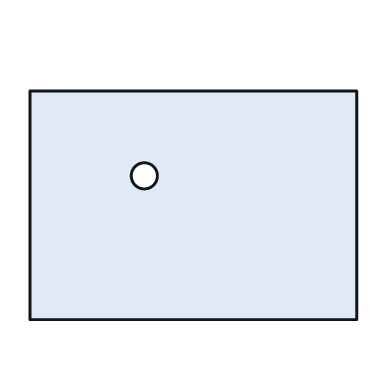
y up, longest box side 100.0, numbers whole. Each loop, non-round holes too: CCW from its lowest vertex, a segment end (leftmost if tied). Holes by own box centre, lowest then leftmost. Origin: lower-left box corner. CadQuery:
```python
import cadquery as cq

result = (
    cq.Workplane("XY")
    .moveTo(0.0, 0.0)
    .lineTo(100.0, 0.0)
    .lineTo(100.0, 70.0)
    .lineTo(0.0, 70.0)
    .close()
    .moveTo(35.0, 44.0)
    .circle(4.0)
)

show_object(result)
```